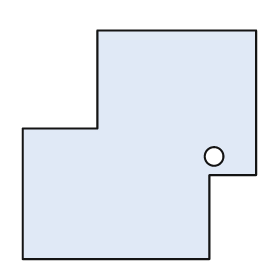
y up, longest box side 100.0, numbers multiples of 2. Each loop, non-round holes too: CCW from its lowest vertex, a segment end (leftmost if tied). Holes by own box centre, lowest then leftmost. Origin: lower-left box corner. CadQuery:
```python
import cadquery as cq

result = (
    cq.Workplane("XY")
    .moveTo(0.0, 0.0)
    .lineTo(80.0, 0.0)
    .lineTo(80.0, 36.0)
    .lineTo(100.0, 36.0)
    .lineTo(100.0, 98.0)
    .lineTo(32.0, 98.0)
    .lineTo(32.0, 56.0)
    .lineTo(0.0, 56.0)
    .close()
    .moveTo(82.0, 44.0)
    .circle(4.0)
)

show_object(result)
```